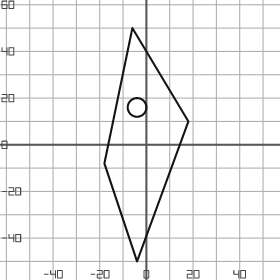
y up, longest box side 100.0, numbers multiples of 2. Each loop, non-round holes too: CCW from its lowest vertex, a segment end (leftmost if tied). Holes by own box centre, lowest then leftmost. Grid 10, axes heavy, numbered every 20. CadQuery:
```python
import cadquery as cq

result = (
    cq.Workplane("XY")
    .moveTo(-4.0, -50.0)
    .lineTo(18.0, 10.0)
    .lineTo(-6.0, 50.0)
    .lineTo(-18.0, -8.0)
    .close()
    .moveTo(-4.0, 16.0)
    .circle(4.0)
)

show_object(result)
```